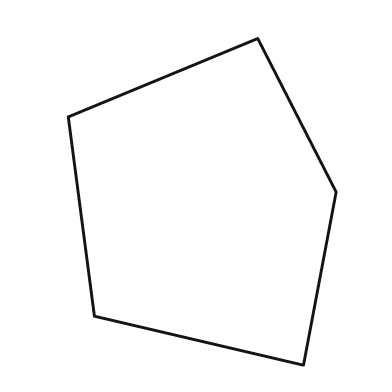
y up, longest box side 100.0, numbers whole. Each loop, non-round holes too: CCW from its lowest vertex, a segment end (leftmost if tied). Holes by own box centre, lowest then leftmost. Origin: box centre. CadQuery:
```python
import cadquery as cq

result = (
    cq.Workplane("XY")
    .moveTo(31.0, -50.0)
    .lineTo(41.0, 3.0)
    .lineTo(17.0, 50.0)
    .lineTo(-41.0, 26.0)
    .lineTo(-33.0, -35.0)
    .close()
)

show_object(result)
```